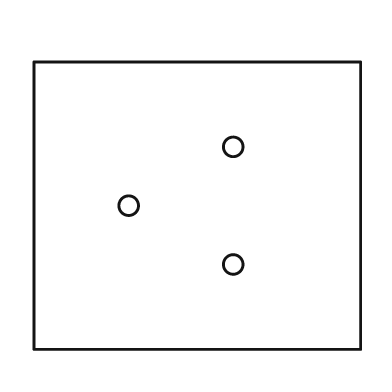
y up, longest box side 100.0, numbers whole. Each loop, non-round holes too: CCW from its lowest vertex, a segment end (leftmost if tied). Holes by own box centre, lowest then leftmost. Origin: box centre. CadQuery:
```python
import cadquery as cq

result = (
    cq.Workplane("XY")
    .moveTo(-50.0, -44.0)
    .lineTo(50.0, -44.0)
    .lineTo(50.0, 44.0)
    .lineTo(-50.0, 44.0)
    .close()
    .moveTo(11.0, -18.0)
    .circle(3.0)
    .moveTo(-21.0, 0.0)
    .circle(3.0)
    .moveTo(11.0, 18.0)
    .circle(3.0)
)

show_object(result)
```